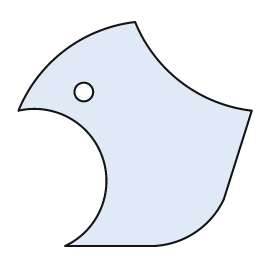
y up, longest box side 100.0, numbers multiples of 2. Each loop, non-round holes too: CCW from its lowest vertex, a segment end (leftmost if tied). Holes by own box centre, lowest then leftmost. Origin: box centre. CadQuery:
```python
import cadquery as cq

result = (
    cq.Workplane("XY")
    .moveTo(-30.0, -48.0)
    .lineTo(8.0, -48.0)
    .threePointArc((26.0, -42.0), (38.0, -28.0))
    .lineTo(50.0, 10.0)
    .threePointArc((20.0, 22.0), (0.0, 48.0))
    .threePointArc((-30.0, 36.0), (-50.0, 10.0))
    .threePointArc((-14.0, -10.0), (-30.0, -48.0))
    .close()
    .moveTo(-22.0, 18.0)
    .circle(4.0)
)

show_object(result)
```